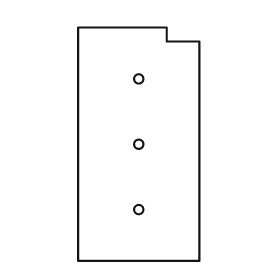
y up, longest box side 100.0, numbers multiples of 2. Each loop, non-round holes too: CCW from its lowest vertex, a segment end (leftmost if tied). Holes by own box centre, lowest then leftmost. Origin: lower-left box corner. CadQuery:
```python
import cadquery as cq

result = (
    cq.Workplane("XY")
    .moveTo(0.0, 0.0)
    .lineTo(52.0, 0.0)
    .lineTo(52.0, 94.0)
    .lineTo(38.0, 94.0)
    .lineTo(38.0, 100.0)
    .lineTo(0.0, 100.0)
    .close()
    .moveTo(26.0, 22.0)
    .circle(2.0)
    .moveTo(26.0, 50.0)
    .circle(2.0)
    .moveTo(26.0, 78.0)
    .circle(2.0)
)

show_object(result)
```